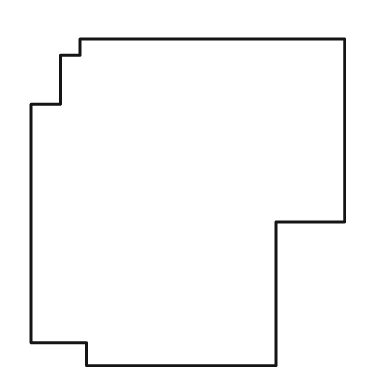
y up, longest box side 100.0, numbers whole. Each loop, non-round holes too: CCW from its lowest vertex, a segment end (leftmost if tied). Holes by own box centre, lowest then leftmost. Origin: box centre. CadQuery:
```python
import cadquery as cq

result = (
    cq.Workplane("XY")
    .moveTo(-31.0, -50.0)
    .lineTo(27.0, -50.0)
    .lineTo(27.0, -6.0)
    .lineTo(48.0, -6.0)
    .lineTo(48.0, 50.0)
    .lineTo(-33.0, 50.0)
    .lineTo(-33.0, 45.0)
    .lineTo(-39.0, 45.0)
    .lineTo(-39.0, 30.0)
    .lineTo(-48.0, 30.0)
    .lineTo(-48.0, -43.0)
    .lineTo(-31.0, -43.0)
    .close()
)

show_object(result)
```